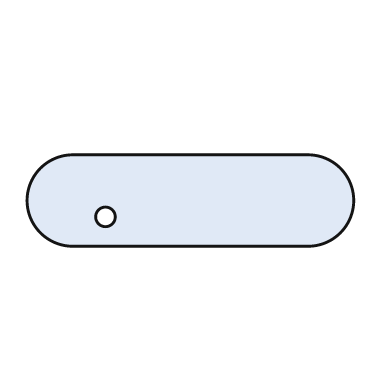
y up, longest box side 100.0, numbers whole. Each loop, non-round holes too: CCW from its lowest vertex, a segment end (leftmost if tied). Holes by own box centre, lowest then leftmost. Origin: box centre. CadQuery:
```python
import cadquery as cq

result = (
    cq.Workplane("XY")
    .moveTo(-36.0, -14.0)
    .lineTo(36.0, -14.0)
    .threePointArc((50.0, 0.0), (36.0, 14.0))
    .lineTo(-36.0, 14.0)
    .threePointArc((-50.0, 0.0), (-36.0, -14.0))
    .close()
    .moveTo(-26.0, -5.0)
    .circle(3.0)
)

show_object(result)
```